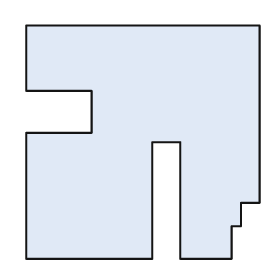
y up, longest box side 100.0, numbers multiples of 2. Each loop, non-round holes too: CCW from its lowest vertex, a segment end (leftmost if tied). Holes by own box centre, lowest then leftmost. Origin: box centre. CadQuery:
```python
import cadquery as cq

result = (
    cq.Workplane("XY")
    .moveTo(-50.0, -50.0)
    .lineTo(4.0, -50.0)
    .lineTo(4.0, 0.0)
    .lineTo(16.0, 0.0)
    .lineTo(16.0, -50.0)
    .lineTo(38.0, -50.0)
    .lineTo(38.0, -36.0)
    .lineTo(42.0, -36.0)
    .lineTo(42.0, -26.0)
    .lineTo(50.0, -26.0)
    .lineTo(50.0, 50.0)
    .lineTo(-50.0, 50.0)
    .lineTo(-50.0, 22.0)
    .lineTo(-22.0, 22.0)
    .lineTo(-22.0, 4.0)
    .lineTo(-50.0, 4.0)
    .close()
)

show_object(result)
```